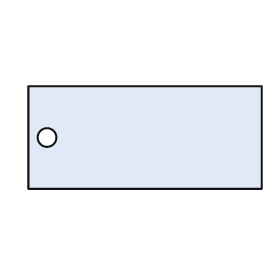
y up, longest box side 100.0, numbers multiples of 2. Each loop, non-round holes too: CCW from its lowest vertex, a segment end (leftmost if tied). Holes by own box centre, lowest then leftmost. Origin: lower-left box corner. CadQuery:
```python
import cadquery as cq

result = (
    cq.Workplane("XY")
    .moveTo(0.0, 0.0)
    .lineTo(100.0, 0.0)
    .lineTo(100.0, 44.0)
    .lineTo(0.0, 44.0)
    .close()
    .moveTo(8.0, 22.0)
    .circle(4.0)
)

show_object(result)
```